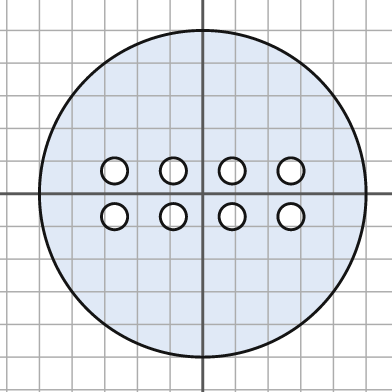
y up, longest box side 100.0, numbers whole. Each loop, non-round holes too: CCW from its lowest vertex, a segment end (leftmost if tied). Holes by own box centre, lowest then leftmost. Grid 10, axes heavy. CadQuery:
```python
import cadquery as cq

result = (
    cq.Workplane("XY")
    .moveTo(0.0, 0.0)
    .circle(50.0)
    .moveTo(-27.0, -7.0)
    .circle(4.0)
    .moveTo(-9.0, -7.0)
    .circle(4.0)
    .moveTo(9.0, -7.0)
    .circle(4.0)
    .moveTo(27.0, -7.0)
    .circle(4.0)
    .moveTo(-27.0, 7.0)
    .circle(4.0)
    .moveTo(-9.0, 7.0)
    .circle(4.0)
    .moveTo(9.0, 7.0)
    .circle(4.0)
    .moveTo(27.0, 7.0)
    .circle(4.0)
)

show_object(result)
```